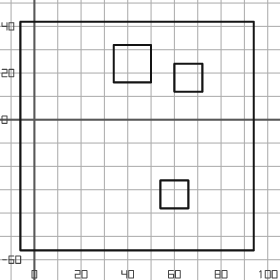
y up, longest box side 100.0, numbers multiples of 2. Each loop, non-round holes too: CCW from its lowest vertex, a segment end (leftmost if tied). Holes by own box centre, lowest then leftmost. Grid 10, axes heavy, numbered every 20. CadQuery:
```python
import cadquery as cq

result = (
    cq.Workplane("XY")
    .moveTo(-6.0, -56.0)
    .lineTo(94.0, -56.0)
    .lineTo(94.0, 42.0)
    .lineTo(-6.0, 42.0)
    .close()
    .moveTo(54.0, -38.0)
    .lineTo(66.0, -38.0)
    .lineTo(66.0, -26.0)
    .lineTo(54.0, -26.0)
    .close()
    .moveTo(60.0, 12.0)
    .lineTo(72.0, 12.0)
    .lineTo(72.0, 24.0)
    .lineTo(60.0, 24.0)
    .close()
    .moveTo(34.0, 16.0)
    .lineTo(50.0, 16.0)
    .lineTo(50.0, 32.0)
    .lineTo(34.0, 32.0)
    .close()
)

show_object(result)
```